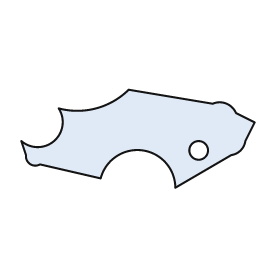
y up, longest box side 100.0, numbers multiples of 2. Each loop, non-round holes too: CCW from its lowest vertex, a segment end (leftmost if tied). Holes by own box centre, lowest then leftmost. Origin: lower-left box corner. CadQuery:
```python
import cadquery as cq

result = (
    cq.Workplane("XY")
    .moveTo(66.0, 0.0)
    .lineTo(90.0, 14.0)
    .threePointArc((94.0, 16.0), (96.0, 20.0))
    .lineTo(100.0, 28.0)
    .lineTo(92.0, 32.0)
    .threePointArc((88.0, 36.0), (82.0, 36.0))
    .lineTo(46.0, 42.0)
    .threePointArc((32.0, 34.0), (16.0, 34.0))
    .threePointArc((14.0, 20.0), (0.0, 20.0))
    .lineTo(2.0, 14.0)
    .threePointArc((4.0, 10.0), (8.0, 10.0))
    .lineTo(34.0, 4.0)
    .threePointArc((52.0, 16.0), (66.0, 0.0))
    .close()
    .moveTo(76.0, 16.0)
    .circle(4.0)
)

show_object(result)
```